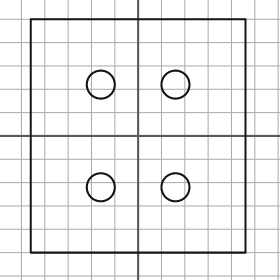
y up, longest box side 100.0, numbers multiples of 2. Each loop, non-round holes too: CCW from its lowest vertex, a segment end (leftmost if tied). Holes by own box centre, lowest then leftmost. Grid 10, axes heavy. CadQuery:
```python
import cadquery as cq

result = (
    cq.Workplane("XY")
    .moveTo(-46.0, -50.0)
    .lineTo(46.0, -50.0)
    .lineTo(46.0, 50.0)
    .lineTo(-46.0, 50.0)
    .close()
    .moveTo(-16.0, -22.0)
    .circle(6.0)
    .moveTo(16.0, -22.0)
    .circle(6.0)
    .moveTo(-16.0, 22.0)
    .circle(6.0)
    .moveTo(16.0, 22.0)
    .circle(6.0)
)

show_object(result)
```